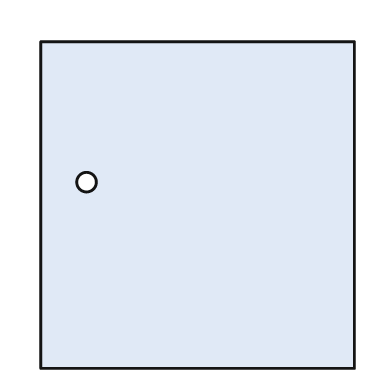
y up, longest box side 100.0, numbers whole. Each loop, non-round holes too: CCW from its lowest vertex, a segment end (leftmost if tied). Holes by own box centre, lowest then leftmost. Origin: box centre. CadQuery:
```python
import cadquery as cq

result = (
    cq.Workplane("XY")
    .moveTo(-48.0, -50.0)
    .lineTo(48.0, -50.0)
    .lineTo(48.0, 50.0)
    .lineTo(-48.0, 50.0)
    .close()
    .moveTo(-34.0, 7.0)
    .circle(3.0)
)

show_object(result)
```